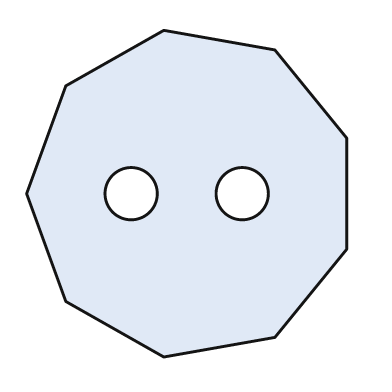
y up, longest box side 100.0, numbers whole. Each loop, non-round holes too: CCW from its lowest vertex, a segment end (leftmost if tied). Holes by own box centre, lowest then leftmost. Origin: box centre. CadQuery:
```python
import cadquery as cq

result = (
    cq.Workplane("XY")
    .moveTo(-7.0, -50.0)
    .lineTo(27.0, -44.0)
    .lineTo(49.0, -17.0)
    .lineTo(49.0, 17.0)
    .lineTo(27.0, 44.0)
    .lineTo(-7.0, 50.0)
    .lineTo(-37.0, 33.0)
    .lineTo(-49.0, 0.0)
    .lineTo(-37.0, -33.0)
    .close()
    .moveTo(-17.0, 0.0)
    .circle(8.0)
    .moveTo(17.0, 0.0)
    .circle(8.0)
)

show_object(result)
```